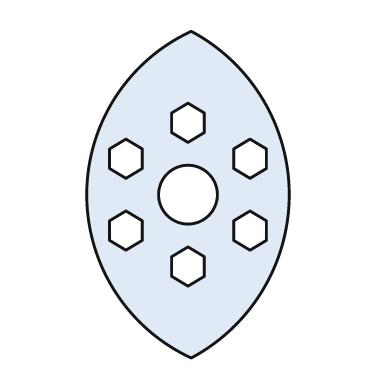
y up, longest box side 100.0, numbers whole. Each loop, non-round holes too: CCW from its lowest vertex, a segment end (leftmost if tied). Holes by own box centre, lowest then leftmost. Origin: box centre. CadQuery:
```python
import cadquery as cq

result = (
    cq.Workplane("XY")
    .moveTo(1.0, -50.0)
    .threePointArc((31.0, 0.0), (1.0, 50.0))
    .threePointArc((-31.0, 0.0), (1.0, -50.0))
    .close()
    .moveTo(0.0, -28.0)
    .lineTo(5.0, -25.0)
    .lineTo(5.0, -19.0)
    .lineTo(0.0, -16.0)
    .lineTo(-5.0, -19.0)
    .lineTo(-5.0, -25.0)
    .close()
    .moveTo(-19.0, -17.0)
    .lineTo(-14.0, -14.0)
    .lineTo(-14.0, -8.0)
    .lineTo(-19.0, -5.0)
    .lineTo(-24.0, -8.0)
    .lineTo(-24.0, -14.0)
    .close()
    .moveTo(19.0, -17.0)
    .lineTo(24.0, -14.0)
    .lineTo(24.0, -8.0)
    .lineTo(19.0, -5.0)
    .lineTo(14.0, -8.0)
    .lineTo(14.0, -14.0)
    .close()
    .moveTo(0.0, 0.0)
    .circle(9.0)
    .moveTo(-19.0, 5.0)
    .lineTo(-14.0, 8.0)
    .lineTo(-14.0, 14.0)
    .lineTo(-19.0, 17.0)
    .lineTo(-24.0, 14.0)
    .lineTo(-24.0, 8.0)
    .close()
    .moveTo(19.0, 5.0)
    .lineTo(24.0, 8.0)
    .lineTo(24.0, 14.0)
    .lineTo(19.0, 17.0)
    .lineTo(14.0, 14.0)
    .lineTo(14.0, 8.0)
    .close()
    .moveTo(0.0, 16.0)
    .lineTo(5.0, 19.0)
    .lineTo(5.0, 25.0)
    .lineTo(0.0, 28.0)
    .lineTo(-5.0, 25.0)
    .lineTo(-5.0, 19.0)
    .close()
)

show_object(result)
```